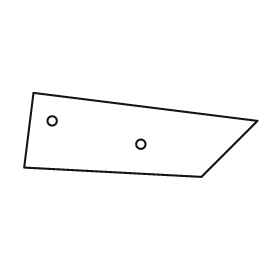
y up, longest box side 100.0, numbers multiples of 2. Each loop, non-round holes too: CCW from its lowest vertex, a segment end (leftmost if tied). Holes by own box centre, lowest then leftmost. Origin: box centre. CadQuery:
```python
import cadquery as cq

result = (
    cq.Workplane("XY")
    .moveTo(26.0, -18.0)
    .lineTo(50.0, 6.0)
    .lineTo(-46.0, 18.0)
    .lineTo(-50.0, -14.0)
    .close()
    .moveTo(0.0, -4.0)
    .circle(2.0)
    .moveTo(-38.0, 6.0)
    .circle(2.0)
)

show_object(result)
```